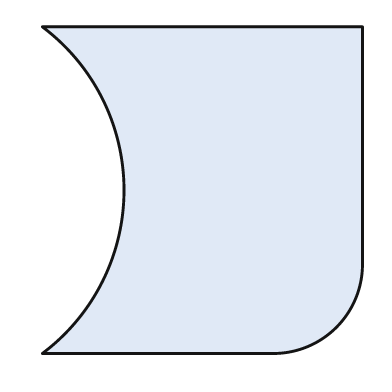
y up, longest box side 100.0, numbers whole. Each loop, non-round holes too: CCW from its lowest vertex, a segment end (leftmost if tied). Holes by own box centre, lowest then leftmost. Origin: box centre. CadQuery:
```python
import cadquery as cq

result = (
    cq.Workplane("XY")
    .moveTo(-49.0, -50.0)
    .lineTo(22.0, -50.0)
    .threePointArc((41.0, -42.0), (49.0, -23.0))
    .lineTo(49.0, 50.0)
    .lineTo(-49.0, 50.0)
    .threePointArc((-24.0, 0.0), (-49.0, -50.0))
    .close()
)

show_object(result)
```